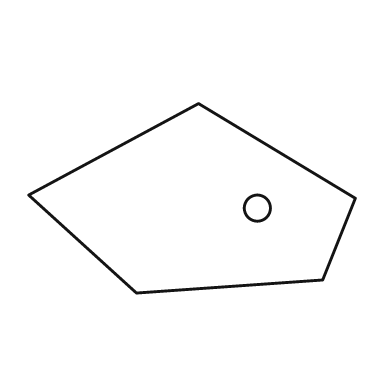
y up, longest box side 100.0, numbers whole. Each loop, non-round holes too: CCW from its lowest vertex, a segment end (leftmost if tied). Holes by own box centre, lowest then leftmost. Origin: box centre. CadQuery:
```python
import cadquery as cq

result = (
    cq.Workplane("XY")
    .moveTo(-17.0, -29.0)
    .lineTo(40.0, -25.0)
    .lineTo(50.0, 0.0)
    .lineTo(2.0, 29.0)
    .lineTo(-50.0, 1.0)
    .close()
    .moveTo(20.0, -3.0)
    .circle(4.0)
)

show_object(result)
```